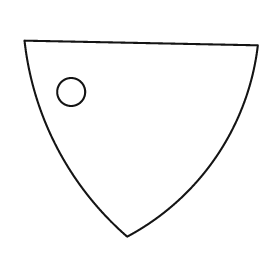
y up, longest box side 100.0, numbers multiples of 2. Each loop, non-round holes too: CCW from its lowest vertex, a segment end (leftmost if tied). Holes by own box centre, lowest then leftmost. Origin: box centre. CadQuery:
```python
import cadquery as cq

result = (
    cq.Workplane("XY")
    .moveTo(-6.0, -42.0)
    .threePointArc((32.0, -8.0), (50.0, 40.0))
    .lineTo(-50.0, 42.0)
    .threePointArc((-36.0, -4.0), (-6.0, -42.0))
    .close()
    .moveTo(-30.0, 20.0)
    .circle(6.0)
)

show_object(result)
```